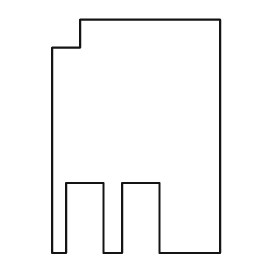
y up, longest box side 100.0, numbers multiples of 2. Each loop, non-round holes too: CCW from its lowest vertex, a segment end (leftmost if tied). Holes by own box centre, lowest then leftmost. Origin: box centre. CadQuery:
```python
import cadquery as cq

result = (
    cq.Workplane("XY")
    .moveTo(-36.0, -50.0)
    .lineTo(-30.0, -50.0)
    .lineTo(-30.0, -20.0)
    .lineTo(-14.0, -20.0)
    .lineTo(-14.0, -50.0)
    .lineTo(-6.0, -50.0)
    .lineTo(-6.0, -20.0)
    .lineTo(10.0, -20.0)
    .lineTo(10.0, -50.0)
    .lineTo(36.0, -50.0)
    .lineTo(36.0, 50.0)
    .lineTo(-24.0, 50.0)
    .lineTo(-24.0, 38.0)
    .lineTo(-36.0, 38.0)
    .close()
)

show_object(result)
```